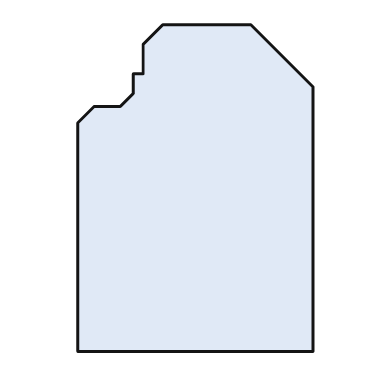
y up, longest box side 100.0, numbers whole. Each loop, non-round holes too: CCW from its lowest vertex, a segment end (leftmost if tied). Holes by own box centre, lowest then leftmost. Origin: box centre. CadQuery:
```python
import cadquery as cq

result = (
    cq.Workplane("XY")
    .moveTo(-36.0, -50.0)
    .lineTo(36.0, -50.0)
    .lineTo(36.0, 31.0)
    .lineTo(17.0, 50.0)
    .lineTo(-10.0, 50.0)
    .lineTo(-16.0, 44.0)
    .lineTo(-16.0, 35.0)
    .lineTo(-19.0, 35.0)
    .lineTo(-19.0, 29.0)
    .lineTo(-23.0, 25.0)
    .lineTo(-31.0, 25.0)
    .lineTo(-36.0, 20.0)
    .close()
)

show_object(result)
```